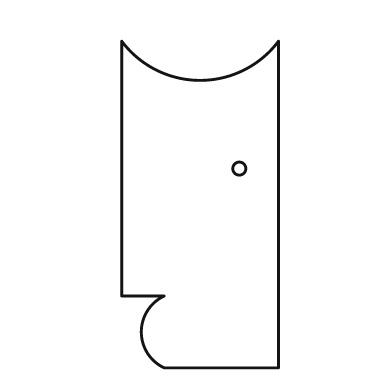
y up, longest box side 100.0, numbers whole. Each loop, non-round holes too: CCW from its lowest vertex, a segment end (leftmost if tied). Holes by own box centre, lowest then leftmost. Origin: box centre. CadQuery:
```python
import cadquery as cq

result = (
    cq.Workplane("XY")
    .moveTo(-11.0, -50.0)
    .lineTo(24.0, -50.0)
    .lineTo(24.0, 50.0)
    .threePointArc((0.0, 38.0), (-24.0, 50.0))
    .lineTo(-24.0, -28.0)
    .lineTo(-11.0, -28.0)
    .threePointArc((-18.0, -39.0), (-11.0, -50.0))
    .close()
    .moveTo(12.0, 11.0)
    .circle(2.0)
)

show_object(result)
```